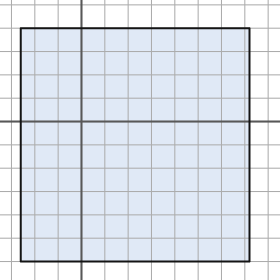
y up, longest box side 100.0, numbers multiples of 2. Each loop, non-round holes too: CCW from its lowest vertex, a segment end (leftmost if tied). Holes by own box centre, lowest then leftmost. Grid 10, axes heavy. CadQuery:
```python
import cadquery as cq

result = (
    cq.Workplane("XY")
    .moveTo(-26.0, -60.0)
    .lineTo(72.0, -60.0)
    .lineTo(72.0, 40.0)
    .lineTo(-26.0, 40.0)
    .close()
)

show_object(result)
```